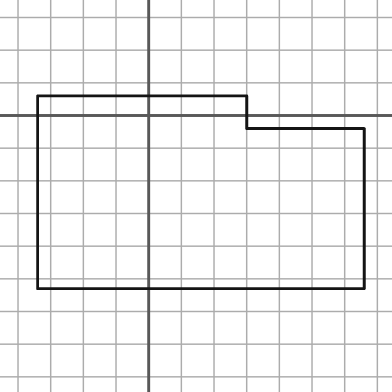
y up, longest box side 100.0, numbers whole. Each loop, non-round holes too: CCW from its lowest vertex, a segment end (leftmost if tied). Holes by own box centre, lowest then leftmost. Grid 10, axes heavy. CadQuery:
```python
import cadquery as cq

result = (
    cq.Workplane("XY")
    .moveTo(-34.0, -53.0)
    .lineTo(66.0, -53.0)
    .lineTo(66.0, -4.0)
    .lineTo(30.0, -4.0)
    .lineTo(30.0, 6.0)
    .lineTo(-34.0, 6.0)
    .close()
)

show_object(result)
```